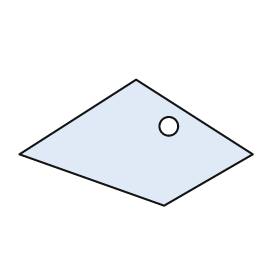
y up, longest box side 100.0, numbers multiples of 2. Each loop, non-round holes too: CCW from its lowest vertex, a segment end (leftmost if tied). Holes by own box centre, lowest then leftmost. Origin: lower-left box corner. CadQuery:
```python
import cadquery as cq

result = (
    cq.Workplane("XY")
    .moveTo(62.0, 0.0)
    .lineTo(100.0, 22.0)
    .lineTo(50.0, 54.0)
    .lineTo(0.0, 22.0)
    .close()
    .moveTo(64.0, 34.0)
    .circle(4.0)
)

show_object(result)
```